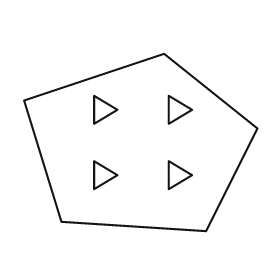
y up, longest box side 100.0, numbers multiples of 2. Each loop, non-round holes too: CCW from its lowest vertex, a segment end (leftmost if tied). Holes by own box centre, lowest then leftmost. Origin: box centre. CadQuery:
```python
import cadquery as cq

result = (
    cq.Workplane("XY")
    .moveTo(28.0, -38.0)
    .lineTo(50.0, 6.0)
    .lineTo(10.0, 38.0)
    .lineTo(-50.0, 18.0)
    .lineTo(-34.0, -34.0)
    .close()
    .moveTo(-20.0, -20.0)
    .lineTo(-10.0, -14.0)
    .lineTo(-20.0, -8.0)
    .close()
    .moveTo(12.0, -20.0)
    .lineTo(22.0, -14.0)
    .lineTo(12.0, -8.0)
    .close()
    .moveTo(-20.0, 8.0)
    .lineTo(-10.0, 14.0)
    .lineTo(-20.0, 20.0)
    .close()
    .moveTo(12.0, 8.0)
    .lineTo(22.0, 14.0)
    .lineTo(12.0, 20.0)
    .close()
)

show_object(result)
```